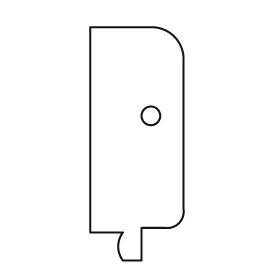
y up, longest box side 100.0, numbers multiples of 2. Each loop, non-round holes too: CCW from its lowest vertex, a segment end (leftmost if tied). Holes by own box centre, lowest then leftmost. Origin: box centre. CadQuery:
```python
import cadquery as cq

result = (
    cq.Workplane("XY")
    .moveTo(-6.0, -50.0)
    .lineTo(2.0, -50.0)
    .lineTo(2.0, -36.0)
    .lineTo(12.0, -36.0)
    .threePointArc((18.0, -34.0), (20.0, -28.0))
    .lineTo(20.0, 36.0)
    .threePointArc((16.0, 46.0), (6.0, 50.0))
    .lineTo(-20.0, 50.0)
    .lineTo(-20.0, -38.0)
    .lineTo(-6.0, -38.0)
    .threePointArc((-8.0, -44.0), (-6.0, -50.0))
    .close()
    .moveTo(6.0, 12.0)
    .circle(4.0)
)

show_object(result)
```